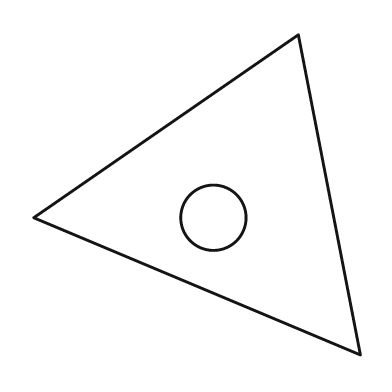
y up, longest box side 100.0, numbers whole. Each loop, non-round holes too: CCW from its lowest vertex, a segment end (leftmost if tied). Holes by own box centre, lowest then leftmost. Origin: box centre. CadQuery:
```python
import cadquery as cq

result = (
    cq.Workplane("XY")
    .moveTo(50.0, -49.0)
    .lineTo(31.0, 49.0)
    .lineTo(-50.0, -7.0)
    .close()
    .moveTo(5.0, -7.0)
    .circle(10.0)
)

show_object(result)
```